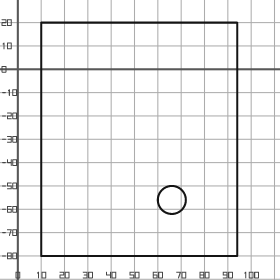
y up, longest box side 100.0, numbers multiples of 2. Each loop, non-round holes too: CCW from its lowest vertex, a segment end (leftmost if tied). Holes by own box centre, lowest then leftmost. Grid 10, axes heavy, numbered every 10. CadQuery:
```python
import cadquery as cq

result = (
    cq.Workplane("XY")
    .moveTo(10.0, -80.0)
    .lineTo(94.0, -80.0)
    .lineTo(94.0, 20.0)
    .lineTo(10.0, 20.0)
    .close()
    .moveTo(66.0, -56.0)
    .circle(6.0)
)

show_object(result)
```